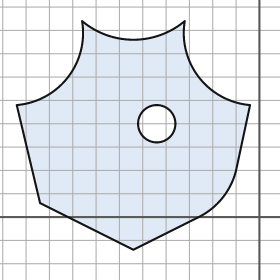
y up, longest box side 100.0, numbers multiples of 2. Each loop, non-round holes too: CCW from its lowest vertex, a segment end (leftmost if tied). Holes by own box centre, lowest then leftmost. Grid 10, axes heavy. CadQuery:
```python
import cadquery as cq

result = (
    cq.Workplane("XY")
    .moveTo(-54.0, -14.0)
    .lineTo(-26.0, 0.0)
    .threePointArc((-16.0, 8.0), (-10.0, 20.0))
    .lineTo(-4.0, 48.0)
    .threePointArc((-26.0, 60.0), (-32.0, 84.0))
    .threePointArc((-54.0, 76.0), (-76.0, 84.0))
    .threePointArc((-82.0, 60.0), (-104.0, 48.0))
    .lineTo(-94.0, 6.0)
    .close()
    .moveTo(-44.0, 40.0)
    .circle(8.0)
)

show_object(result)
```